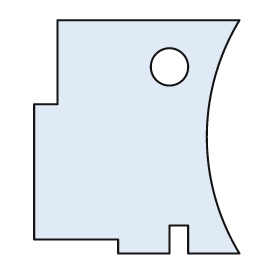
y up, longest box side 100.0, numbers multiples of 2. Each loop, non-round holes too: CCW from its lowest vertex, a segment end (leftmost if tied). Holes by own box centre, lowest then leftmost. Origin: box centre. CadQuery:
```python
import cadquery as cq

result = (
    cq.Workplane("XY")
    .moveTo(-8.0, -50.0)
    .lineTo(14.0, -50.0)
    .lineTo(14.0, -38.0)
    .lineTo(22.0, -38.0)
    .lineTo(22.0, -50.0)
    .lineTo(44.0, -50.0)
    .threePointArc((30.0, 0.0), (44.0, 50.0))
    .lineTo(-34.0, 50.0)
    .lineTo(-34.0, 14.0)
    .lineTo(-44.0, 14.0)
    .lineTo(-44.0, -44.0)
    .lineTo(-8.0, -44.0)
    .close()
    .moveTo(14.0, 30.0)
    .circle(8.0)
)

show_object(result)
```